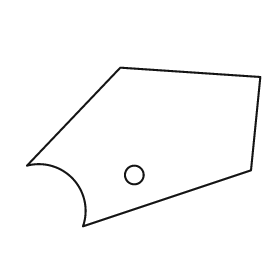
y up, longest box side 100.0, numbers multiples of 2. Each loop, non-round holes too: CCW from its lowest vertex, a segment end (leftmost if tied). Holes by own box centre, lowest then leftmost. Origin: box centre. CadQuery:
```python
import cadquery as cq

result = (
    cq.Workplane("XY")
    .moveTo(-26.0, -34.0)
    .lineTo(46.0, -10.0)
    .lineTo(50.0, 30.0)
    .lineTo(-10.0, 34.0)
    .lineTo(-50.0, -8.0)
    .threePointArc((-30.0, -14.0), (-26.0, -34.0))
    .close()
    .moveTo(-4.0, -12.0)
    .circle(4.0)
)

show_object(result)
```